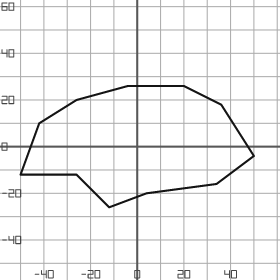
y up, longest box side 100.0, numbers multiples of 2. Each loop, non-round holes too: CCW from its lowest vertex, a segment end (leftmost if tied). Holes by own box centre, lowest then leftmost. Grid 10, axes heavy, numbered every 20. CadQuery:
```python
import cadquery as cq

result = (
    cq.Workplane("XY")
    .moveTo(-12.0, -26.0)
    .lineTo(4.0, -20.0)
    .lineTo(34.0, -16.0)
    .lineTo(50.0, -4.0)
    .lineTo(36.0, 18.0)
    .lineTo(20.0, 26.0)
    .lineTo(-4.0, 26.0)
    .lineTo(-26.0, 20.0)
    .lineTo(-42.0, 10.0)
    .lineTo(-50.0, -12.0)
    .lineTo(-26.0, -12.0)
    .close()
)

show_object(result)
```